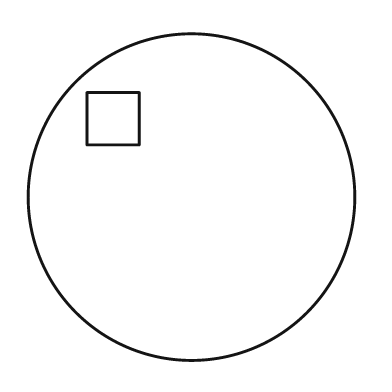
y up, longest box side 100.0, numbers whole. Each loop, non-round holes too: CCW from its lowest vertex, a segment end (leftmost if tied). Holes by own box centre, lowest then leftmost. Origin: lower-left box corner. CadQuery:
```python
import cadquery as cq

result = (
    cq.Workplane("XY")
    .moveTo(50.0, 50.0)
    .circle(50.0)
    .moveTo(18.0, 66.0)
    .lineTo(34.0, 66.0)
    .lineTo(34.0, 82.0)
    .lineTo(18.0, 82.0)
    .close()
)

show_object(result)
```